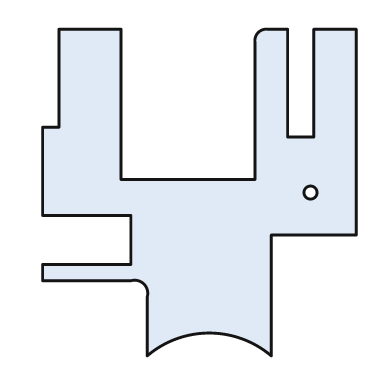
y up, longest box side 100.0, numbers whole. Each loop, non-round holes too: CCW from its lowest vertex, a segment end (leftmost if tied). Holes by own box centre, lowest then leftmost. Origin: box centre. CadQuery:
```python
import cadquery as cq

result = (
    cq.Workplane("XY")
    .moveTo(-16.0, -50.0)
    .threePointArc((3.0, -43.0), (22.0, -50.0))
    .lineTo(22.0, -13.0)
    .lineTo(48.0, -13.0)
    .lineTo(48.0, 50.0)
    .lineTo(35.0, 50.0)
    .lineTo(35.0, 17.0)
    .lineTo(27.0, 17.0)
    .lineTo(27.0, 50.0)
    .lineTo(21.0, 50.0)
    .threePointArc((18.0, 49.0), (17.0, 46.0))
    .lineTo(17.0, 4.0)
    .lineTo(-24.0, 4.0)
    .lineTo(-24.0, 50.0)
    .lineTo(-43.0, 50.0)
    .lineTo(-43.0, 20.0)
    .lineTo(-48.0, 20.0)
    .lineTo(-48.0, -7.0)
    .lineTo(-21.0, -7.0)
    .lineTo(-21.0, -22.0)
    .lineTo(-48.0, -22.0)
    .lineTo(-48.0, -27.0)
    .lineTo(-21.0, -27.0)
    .threePointArc((-17.0, -28.0), (-16.0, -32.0))
    .close()
    .moveTo(34.0, 0.0)
    .circle(2.0)
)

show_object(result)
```